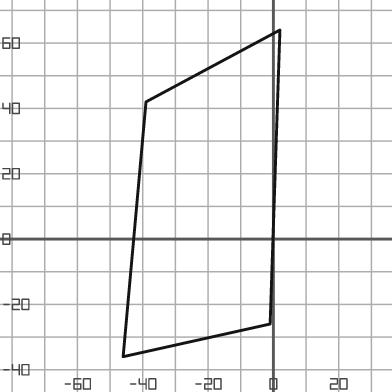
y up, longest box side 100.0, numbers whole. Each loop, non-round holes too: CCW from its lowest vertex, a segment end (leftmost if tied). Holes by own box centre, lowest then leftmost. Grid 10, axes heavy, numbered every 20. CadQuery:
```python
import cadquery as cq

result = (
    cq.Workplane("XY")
    .moveTo(-46.0, -36.0)
    .lineTo(-1.0, -26.0)
    .lineTo(2.0, 64.0)
    .lineTo(-39.0, 42.0)
    .close()
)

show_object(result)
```